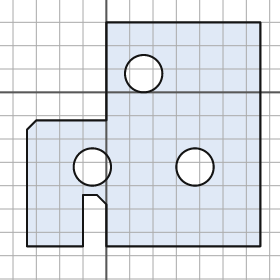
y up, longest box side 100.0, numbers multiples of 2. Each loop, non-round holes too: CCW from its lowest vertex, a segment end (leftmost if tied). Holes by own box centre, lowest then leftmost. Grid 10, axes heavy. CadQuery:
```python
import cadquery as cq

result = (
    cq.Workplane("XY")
    .moveTo(-34.0, -66.0)
    .lineTo(-10.0, -66.0)
    .lineTo(-10.0, -44.0)
    .lineTo(-4.0, -44.0)
    .lineTo(0.0, -48.0)
    .lineTo(0.0, -66.0)
    .lineTo(66.0, -66.0)
    .lineTo(66.0, 30.0)
    .lineTo(0.0, 30.0)
    .lineTo(0.0, -12.0)
    .lineTo(-30.0, -12.0)
    .lineTo(-34.0, -16.0)
    .close()
    .moveTo(-6.0, -32.0)
    .circle(8.0)
    .moveTo(38.0, -32.0)
    .circle(8.0)
    .moveTo(16.0, 8.0)
    .circle(8.0)
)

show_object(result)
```